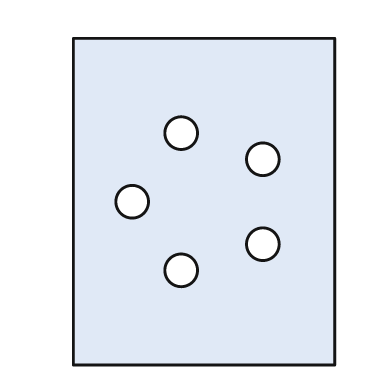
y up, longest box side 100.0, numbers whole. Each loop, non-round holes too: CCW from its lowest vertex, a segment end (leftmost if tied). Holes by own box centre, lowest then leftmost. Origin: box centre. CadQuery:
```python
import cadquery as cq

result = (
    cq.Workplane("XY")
    .moveTo(-40.0, -50.0)
    .lineTo(40.0, -50.0)
    .lineTo(40.0, 50.0)
    .lineTo(-40.0, 50.0)
    .close()
    .moveTo(-7.0, -21.0)
    .circle(5.0)
    .moveTo(18.0, -13.0)
    .circle(5.0)
    .moveTo(-22.0, 0.0)
    .circle(5.0)
    .moveTo(18.0, 13.0)
    .circle(5.0)
    .moveTo(-7.0, 21.0)
    .circle(5.0)
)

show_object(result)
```